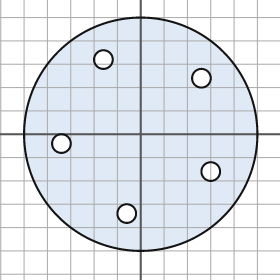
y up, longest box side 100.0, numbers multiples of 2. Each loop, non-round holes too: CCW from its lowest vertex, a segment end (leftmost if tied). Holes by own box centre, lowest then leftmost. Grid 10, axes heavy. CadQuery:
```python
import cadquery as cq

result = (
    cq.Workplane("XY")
    .moveTo(0.0, 0.0)
    .circle(50.0)
    .moveTo(-6.0, -34.0)
    .circle(4.0)
    .moveTo(30.0, -16.0)
    .circle(4.0)
    .moveTo(-34.0, -4.0)
    .circle(4.0)
    .moveTo(26.0, 24.0)
    .circle(4.0)
    .moveTo(-16.0, 32.0)
    .circle(4.0)
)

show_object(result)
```